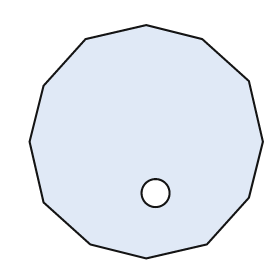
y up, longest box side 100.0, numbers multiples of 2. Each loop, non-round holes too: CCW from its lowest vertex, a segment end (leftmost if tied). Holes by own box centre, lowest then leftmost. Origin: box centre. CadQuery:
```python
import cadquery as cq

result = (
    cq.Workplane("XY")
    .moveTo(0.0, -50.0)
    .lineTo(26.0, -44.0)
    .lineTo(44.0, -24.0)
    .lineTo(50.0, 0.0)
    .lineTo(44.0, 26.0)
    .lineTo(24.0, 44.0)
    .lineTo(0.0, 50.0)
    .lineTo(-26.0, 44.0)
    .lineTo(-44.0, 24.0)
    .lineTo(-50.0, 0.0)
    .lineTo(-44.0, -26.0)
    .lineTo(-24.0, -44.0)
    .close()
    .moveTo(4.0, -22.0)
    .circle(6.0)
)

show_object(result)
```